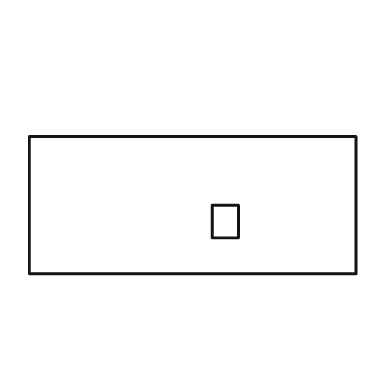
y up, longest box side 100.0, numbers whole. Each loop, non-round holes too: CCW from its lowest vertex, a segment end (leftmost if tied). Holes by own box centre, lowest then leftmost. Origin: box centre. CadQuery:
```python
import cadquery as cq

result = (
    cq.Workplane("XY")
    .moveTo(-50.0, -21.0)
    .lineTo(50.0, -21.0)
    .lineTo(50.0, 21.0)
    .lineTo(-50.0, 21.0)
    .close()
    .moveTo(6.0, -10.0)
    .lineTo(14.0, -10.0)
    .lineTo(14.0, 0.0)
    .lineTo(6.0, 0.0)
    .close()
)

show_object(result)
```